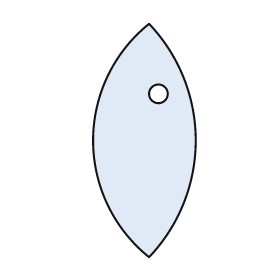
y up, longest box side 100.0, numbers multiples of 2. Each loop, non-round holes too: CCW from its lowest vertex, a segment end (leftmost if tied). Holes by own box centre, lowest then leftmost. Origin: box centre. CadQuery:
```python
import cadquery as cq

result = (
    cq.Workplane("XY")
    .moveTo(2.0, -50.0)
    .threePointArc((22.0, 0.0), (2.0, 50.0))
    .threePointArc((-22.0, 0.0), (2.0, -50.0))
    .close()
    .moveTo(6.0, 20.0)
    .circle(4.0)
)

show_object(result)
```